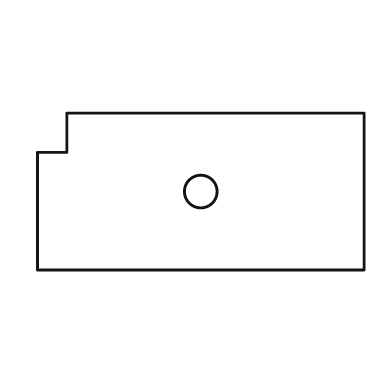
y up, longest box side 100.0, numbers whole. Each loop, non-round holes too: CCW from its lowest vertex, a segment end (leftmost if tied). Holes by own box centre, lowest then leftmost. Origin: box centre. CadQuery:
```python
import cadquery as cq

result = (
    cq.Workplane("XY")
    .moveTo(-50.0, -24.0)
    .lineTo(50.0, -24.0)
    .lineTo(50.0, 24.0)
    .lineTo(-41.0, 24.0)
    .lineTo(-41.0, 12.0)
    .lineTo(-50.0, 12.0)
    .close()
    .moveTo(0.0, 0.0)
    .circle(5.0)
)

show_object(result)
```